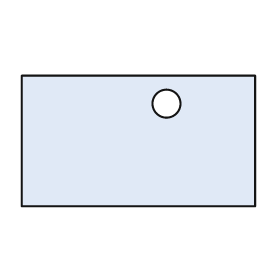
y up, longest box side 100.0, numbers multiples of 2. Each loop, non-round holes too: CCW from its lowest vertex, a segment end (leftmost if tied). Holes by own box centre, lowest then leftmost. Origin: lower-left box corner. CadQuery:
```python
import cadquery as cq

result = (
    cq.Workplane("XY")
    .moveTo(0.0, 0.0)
    .lineTo(100.0, 0.0)
    .lineTo(100.0, 56.0)
    .lineTo(0.0, 56.0)
    .close()
    .moveTo(62.0, 44.0)
    .circle(6.0)
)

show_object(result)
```